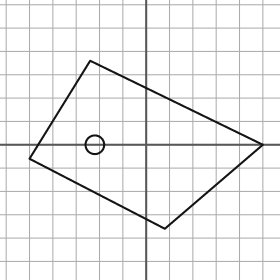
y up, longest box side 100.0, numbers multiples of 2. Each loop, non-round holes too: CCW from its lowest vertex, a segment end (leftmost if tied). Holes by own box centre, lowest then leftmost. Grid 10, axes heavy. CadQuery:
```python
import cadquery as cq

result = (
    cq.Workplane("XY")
    .moveTo(8.0, -36.0)
    .lineTo(50.0, 0.0)
    .lineTo(-24.0, 36.0)
    .lineTo(-50.0, -6.0)
    .close()
    .moveTo(-22.0, 0.0)
    .circle(4.0)
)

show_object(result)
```